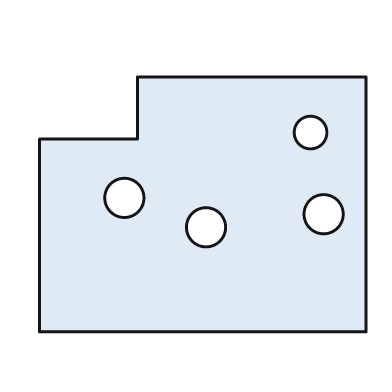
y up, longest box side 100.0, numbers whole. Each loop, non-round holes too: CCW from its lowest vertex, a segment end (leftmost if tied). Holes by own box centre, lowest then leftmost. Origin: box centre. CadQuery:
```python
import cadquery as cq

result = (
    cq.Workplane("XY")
    .moveTo(-50.0, -39.0)
    .lineTo(50.0, -39.0)
    .lineTo(50.0, 39.0)
    .lineTo(-20.0, 39.0)
    .lineTo(-20.0, 20.0)
    .lineTo(-50.0, 20.0)
    .close()
    .moveTo(1.0, -7.0)
    .circle(6.0)
    .moveTo(37.0, -3.0)
    .circle(6.0)
    .moveTo(-24.0, 2.0)
    .circle(6.0)
    .moveTo(33.0, 22.0)
    .circle(5.0)
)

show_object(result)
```